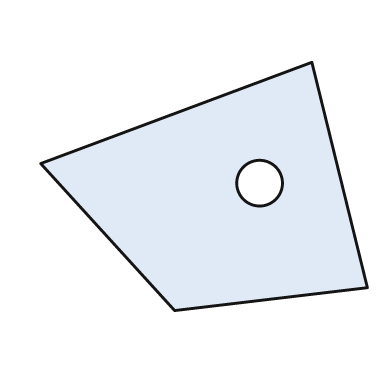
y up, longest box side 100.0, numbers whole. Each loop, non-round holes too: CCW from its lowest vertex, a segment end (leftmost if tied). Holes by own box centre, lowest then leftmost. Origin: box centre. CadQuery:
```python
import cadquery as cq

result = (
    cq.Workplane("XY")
    .moveTo(-9.0, -38.0)
    .lineTo(50.0, -31.0)
    .lineTo(33.0, 38.0)
    .lineTo(-50.0, 7.0)
    .close()
    .moveTo(17.0, 1.0)
    .circle(7.0)
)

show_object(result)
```